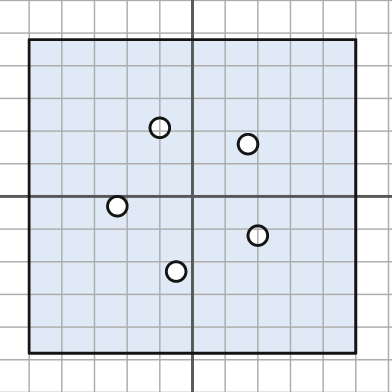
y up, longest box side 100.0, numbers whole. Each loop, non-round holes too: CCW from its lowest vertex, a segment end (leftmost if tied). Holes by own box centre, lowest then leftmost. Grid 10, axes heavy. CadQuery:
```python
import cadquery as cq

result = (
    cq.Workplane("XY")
    .moveTo(-50.0, -48.0)
    .lineTo(50.0, -48.0)
    .lineTo(50.0, 48.0)
    .lineTo(-50.0, 48.0)
    .close()
    .moveTo(-5.0, -23.0)
    .circle(3.0)
    .moveTo(20.0, -12.0)
    .circle(3.0)
    .moveTo(-23.0, -3.0)
    .circle(3.0)
    .moveTo(17.0, 16.0)
    .circle(3.0)
    .moveTo(-10.0, 21.0)
    .circle(3.0)
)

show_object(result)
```